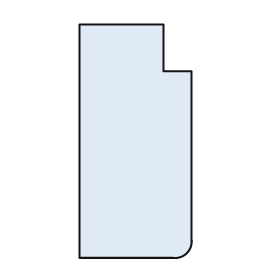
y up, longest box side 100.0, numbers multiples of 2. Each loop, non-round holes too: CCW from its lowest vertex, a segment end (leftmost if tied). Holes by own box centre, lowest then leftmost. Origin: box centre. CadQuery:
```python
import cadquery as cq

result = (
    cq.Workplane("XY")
    .moveTo(-24.0, -50.0)
    .lineTo(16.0, -50.0)
    .threePointArc((22.0, -48.0), (24.0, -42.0))
    .lineTo(24.0, 30.0)
    .lineTo(12.0, 30.0)
    .lineTo(12.0, 50.0)
    .lineTo(-24.0, 50.0)
    .close()
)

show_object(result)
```